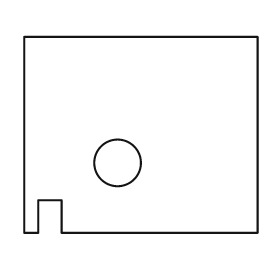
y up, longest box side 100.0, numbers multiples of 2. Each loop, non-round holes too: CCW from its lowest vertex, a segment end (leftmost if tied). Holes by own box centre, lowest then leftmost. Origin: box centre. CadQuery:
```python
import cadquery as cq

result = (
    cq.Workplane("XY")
    .moveTo(-50.0, -42.0)
    .lineTo(-44.0, -42.0)
    .lineTo(-44.0, -28.0)
    .lineTo(-34.0, -28.0)
    .lineTo(-34.0, -42.0)
    .lineTo(50.0, -42.0)
    .lineTo(50.0, 42.0)
    .lineTo(-50.0, 42.0)
    .close()
    .moveTo(-10.0, -12.0)
    .circle(10.0)
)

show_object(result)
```